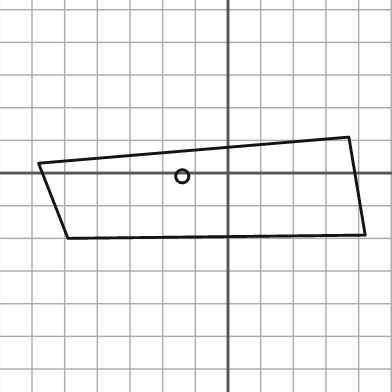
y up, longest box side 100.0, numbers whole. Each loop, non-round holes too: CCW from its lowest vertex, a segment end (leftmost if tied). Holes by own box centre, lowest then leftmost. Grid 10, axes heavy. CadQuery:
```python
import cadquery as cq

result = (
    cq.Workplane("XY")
    .moveTo(-49.0, -20.0)
    .lineTo(42.0, -19.0)
    .lineTo(37.0, 11.0)
    .lineTo(-58.0, 3.0)
    .close()
    .moveTo(-14.0, -1.0)
    .circle(2.0)
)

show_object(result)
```